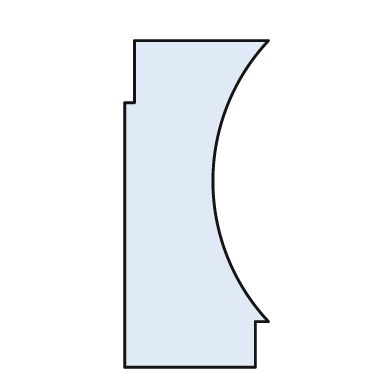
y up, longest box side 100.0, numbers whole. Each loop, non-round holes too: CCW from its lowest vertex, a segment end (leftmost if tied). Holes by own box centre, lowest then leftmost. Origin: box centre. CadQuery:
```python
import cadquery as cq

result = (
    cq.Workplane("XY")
    .moveTo(-22.0, -50.0)
    .lineTo(18.0, -50.0)
    .lineTo(18.0, -36.0)
    .lineTo(22.0, -36.0)
    .threePointArc((5.0, 7.0), (22.0, 50.0))
    .lineTo(-19.0, 50.0)
    .lineTo(-19.0, 31.0)
    .lineTo(-22.0, 31.0)
    .close()
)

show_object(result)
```